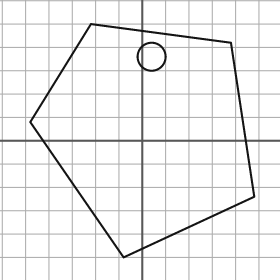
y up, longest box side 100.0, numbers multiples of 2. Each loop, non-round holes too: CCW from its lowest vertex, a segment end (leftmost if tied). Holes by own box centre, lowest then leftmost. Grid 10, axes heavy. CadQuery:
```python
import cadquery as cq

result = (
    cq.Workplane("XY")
    .moveTo(-8.0, -50.0)
    .lineTo(48.0, -24.0)
    .lineTo(38.0, 42.0)
    .lineTo(-22.0, 50.0)
    .lineTo(-48.0, 8.0)
    .close()
    .moveTo(4.0, 36.0)
    .circle(6.0)
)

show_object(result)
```